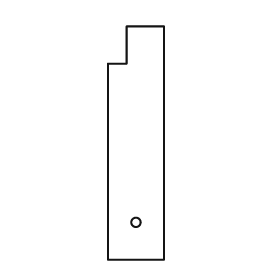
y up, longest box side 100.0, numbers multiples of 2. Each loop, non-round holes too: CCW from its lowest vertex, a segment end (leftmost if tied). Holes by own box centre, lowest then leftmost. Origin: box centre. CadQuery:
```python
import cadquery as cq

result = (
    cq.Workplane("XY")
    .moveTo(-12.0, -50.0)
    .lineTo(12.0, -50.0)
    .lineTo(12.0, 50.0)
    .lineTo(-4.0, 50.0)
    .lineTo(-4.0, 34.0)
    .lineTo(-12.0, 34.0)
    .close()
    .moveTo(0.0, -34.0)
    .circle(2.0)
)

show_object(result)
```